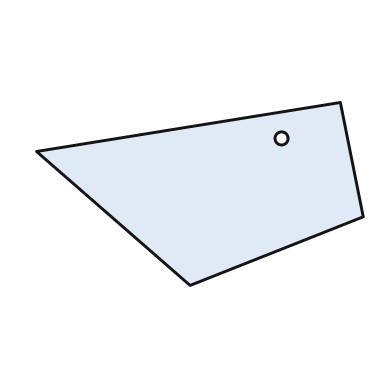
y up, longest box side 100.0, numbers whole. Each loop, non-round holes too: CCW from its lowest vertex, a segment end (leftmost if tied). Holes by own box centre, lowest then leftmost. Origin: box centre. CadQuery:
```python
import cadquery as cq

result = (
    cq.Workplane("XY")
    .moveTo(-3.0, -28.0)
    .lineTo(50.0, -7.0)
    .lineTo(43.0, 28.0)
    .lineTo(-50.0, 13.0)
    .close()
    .moveTo(25.0, 17.0)
    .circle(2.0)
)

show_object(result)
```